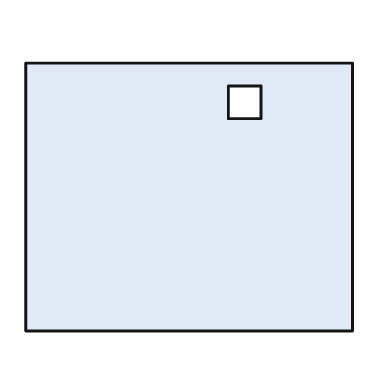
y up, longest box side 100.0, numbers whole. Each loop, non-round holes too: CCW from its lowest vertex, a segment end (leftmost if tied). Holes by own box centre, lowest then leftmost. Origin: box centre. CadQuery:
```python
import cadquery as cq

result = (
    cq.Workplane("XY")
    .moveTo(-50.0, -41.0)
    .lineTo(50.0, -41.0)
    .lineTo(50.0, 41.0)
    .lineTo(-50.0, 41.0)
    .close()
    .moveTo(12.0, 24.0)
    .lineTo(22.0, 24.0)
    .lineTo(22.0, 34.0)
    .lineTo(12.0, 34.0)
    .close()
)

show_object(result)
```